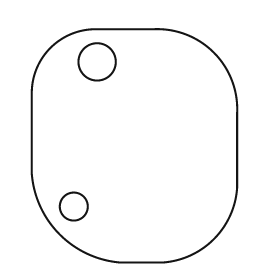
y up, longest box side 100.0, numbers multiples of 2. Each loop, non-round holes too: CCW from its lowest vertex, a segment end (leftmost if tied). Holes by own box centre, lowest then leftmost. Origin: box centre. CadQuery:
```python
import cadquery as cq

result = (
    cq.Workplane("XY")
    .moveTo(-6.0, -50.0)
    .lineTo(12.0, -50.0)
    .threePointArc((34.0, -40.0), (44.0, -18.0))
    .lineTo(44.0, 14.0)
    .threePointArc((34.0, 40.0), (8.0, 50.0))
    .lineTo(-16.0, 50.0)
    .threePointArc((-36.0, 42.0), (-44.0, 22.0))
    .lineTo(-44.0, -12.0)
    .threePointArc((-32.0, -38.0), (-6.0, -50.0))
    .close()
    .moveTo(-26.0, -26.0)
    .circle(6.0)
    .moveTo(-16.0, 36.0)
    .circle(8.0)
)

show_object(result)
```